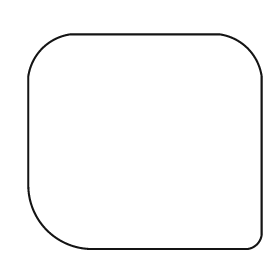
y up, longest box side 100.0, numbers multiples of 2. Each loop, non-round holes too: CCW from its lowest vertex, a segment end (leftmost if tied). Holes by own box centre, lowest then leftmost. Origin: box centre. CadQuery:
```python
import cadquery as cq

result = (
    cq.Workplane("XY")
    .moveTo(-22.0, -46.0)
    .lineTo(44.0, -46.0)
    .threePointArc((48.0, -44.0), (50.0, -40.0))
    .lineTo(50.0, 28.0)
    .threePointArc((44.0, 40.0), (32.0, 46.0))
    .lineTo(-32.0, 46.0)
    .threePointArc((-44.0, 40.0), (-50.0, 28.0))
    .lineTo(-50.0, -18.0)
    .threePointArc((-42.0, -38.0), (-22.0, -46.0))
    .close()
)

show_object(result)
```